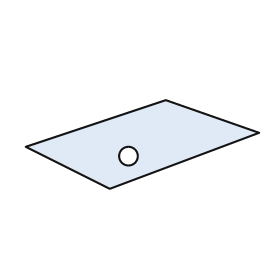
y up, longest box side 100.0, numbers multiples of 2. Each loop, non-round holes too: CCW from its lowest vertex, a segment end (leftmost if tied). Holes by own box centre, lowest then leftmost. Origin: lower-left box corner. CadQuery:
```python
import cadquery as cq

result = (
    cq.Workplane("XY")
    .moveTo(36.0, 0.0)
    .lineTo(100.0, 24.0)
    .lineTo(60.0, 38.0)
    .lineTo(0.0, 18.0)
    .close()
    .moveTo(44.0, 14.0)
    .circle(4.0)
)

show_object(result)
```